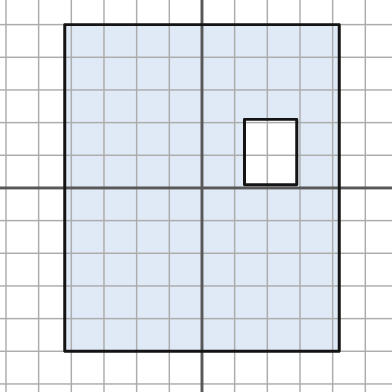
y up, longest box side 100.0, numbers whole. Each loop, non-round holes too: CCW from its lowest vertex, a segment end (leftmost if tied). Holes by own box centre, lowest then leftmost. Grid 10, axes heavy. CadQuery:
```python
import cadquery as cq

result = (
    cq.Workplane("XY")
    .moveTo(-42.0, -50.0)
    .lineTo(42.0, -50.0)
    .lineTo(42.0, 50.0)
    .lineTo(-42.0, 50.0)
    .close()
    .moveTo(13.0, 1.0)
    .lineTo(29.0, 1.0)
    .lineTo(29.0, 21.0)
    .lineTo(13.0, 21.0)
    .close()
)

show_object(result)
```